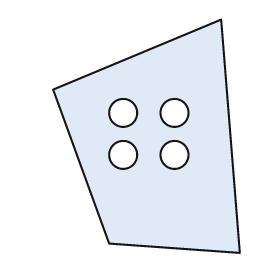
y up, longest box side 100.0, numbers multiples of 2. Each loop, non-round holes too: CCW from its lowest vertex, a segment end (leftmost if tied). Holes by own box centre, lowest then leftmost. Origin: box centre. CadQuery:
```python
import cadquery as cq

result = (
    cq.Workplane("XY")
    .moveTo(40.0, -50.0)
    .lineTo(32.0, 50.0)
    .lineTo(-40.0, 20.0)
    .lineTo(-16.0, -46.0)
    .close()
    .moveTo(-10.0, -8.0)
    .circle(6.0)
    .moveTo(12.0, -8.0)
    .circle(6.0)
    .moveTo(-10.0, 10.0)
    .circle(6.0)
    .moveTo(12.0, 10.0)
    .circle(6.0)
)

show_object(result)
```